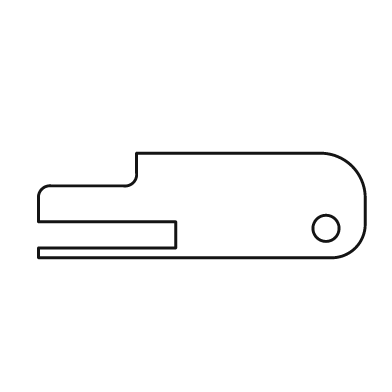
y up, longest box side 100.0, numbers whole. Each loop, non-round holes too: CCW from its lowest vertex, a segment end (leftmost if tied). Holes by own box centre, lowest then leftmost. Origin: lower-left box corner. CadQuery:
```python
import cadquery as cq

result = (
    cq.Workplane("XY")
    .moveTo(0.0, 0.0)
    .lineTo(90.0, 0.0)
    .threePointArc((97.0, 3.0), (100.0, 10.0))
    .lineTo(100.0, 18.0)
    .threePointArc((96.0, 28.0), (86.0, 32.0))
    .lineTo(30.0, 32.0)
    .lineTo(30.0, 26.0)
    .threePointArc((29.0, 23.0), (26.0, 22.0))
    .lineTo(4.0, 22.0)
    .threePointArc((1.0, 21.0), (0.0, 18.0))
    .lineTo(0.0, 11.0)
    .lineTo(42.0, 11.0)
    .lineTo(42.0, 3.0)
    .lineTo(0.0, 3.0)
    .close()
    .moveTo(88.0, 9.0)
    .circle(4.0)
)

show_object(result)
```